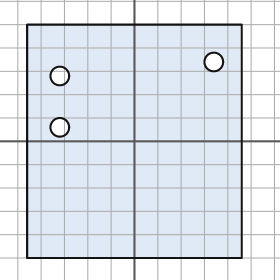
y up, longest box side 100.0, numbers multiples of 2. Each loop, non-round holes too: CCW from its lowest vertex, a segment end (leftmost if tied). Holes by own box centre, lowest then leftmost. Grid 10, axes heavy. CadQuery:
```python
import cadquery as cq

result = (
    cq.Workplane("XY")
    .moveTo(-46.0, -50.0)
    .lineTo(46.0, -50.0)
    .lineTo(46.0, 50.0)
    .lineTo(-46.0, 50.0)
    .close()
    .moveTo(-32.0, 6.0)
    .circle(4.0)
    .moveTo(-32.0, 28.0)
    .circle(4.0)
    .moveTo(34.0, 34.0)
    .circle(4.0)
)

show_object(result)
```